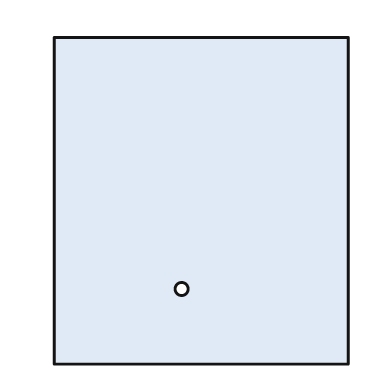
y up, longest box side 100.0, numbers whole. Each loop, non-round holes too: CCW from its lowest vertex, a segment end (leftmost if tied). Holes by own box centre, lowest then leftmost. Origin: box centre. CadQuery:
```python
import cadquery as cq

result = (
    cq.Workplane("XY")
    .moveTo(-45.0, -50.0)
    .lineTo(45.0, -50.0)
    .lineTo(45.0, 50.0)
    .lineTo(-45.0, 50.0)
    .close()
    .moveTo(-6.0, -27.0)
    .circle(2.0)
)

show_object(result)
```